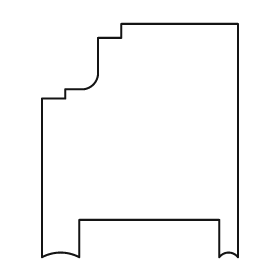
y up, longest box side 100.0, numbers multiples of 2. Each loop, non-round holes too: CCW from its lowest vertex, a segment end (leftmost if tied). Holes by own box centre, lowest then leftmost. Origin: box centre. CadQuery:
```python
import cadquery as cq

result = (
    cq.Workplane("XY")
    .moveTo(-42.0, -50.0)
    .threePointArc((-34.0, -48.0), (-26.0, -50.0))
    .lineTo(-26.0, -34.0)
    .lineTo(34.0, -34.0)
    .lineTo(34.0, -50.0)
    .threePointArc((38.0, -48.0), (42.0, -50.0))
    .lineTo(42.0, 50.0)
    .lineTo(-8.0, 50.0)
    .lineTo(-8.0, 44.0)
    .lineTo(-18.0, 44.0)
    .lineTo(-18.0, 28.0)
    .threePointArc((-20.0, 24.0), (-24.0, 22.0))
    .lineTo(-32.0, 22.0)
    .lineTo(-32.0, 18.0)
    .lineTo(-42.0, 18.0)
    .close()
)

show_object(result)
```